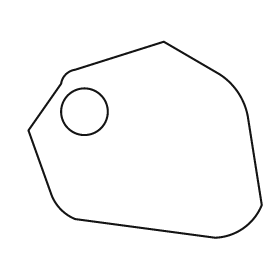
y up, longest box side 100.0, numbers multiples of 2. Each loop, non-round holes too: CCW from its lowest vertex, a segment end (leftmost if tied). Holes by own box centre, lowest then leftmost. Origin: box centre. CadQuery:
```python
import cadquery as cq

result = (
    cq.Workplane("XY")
    .moveTo(30.0, -42.0)
    .threePointArc((42.0, -38.0), (50.0, -28.0))
    .lineTo(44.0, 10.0)
    .threePointArc((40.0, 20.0), (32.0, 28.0))
    .lineTo(8.0, 42.0)
    .lineTo(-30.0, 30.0)
    .threePointArc((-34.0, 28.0), (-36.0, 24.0))
    .lineTo(-50.0, 4.0)
    .lineTo(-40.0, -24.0)
    .threePointArc((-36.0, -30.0), (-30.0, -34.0))
    .close()
    .moveTo(-26.0, 12.0)
    .circle(10.0)
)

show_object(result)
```